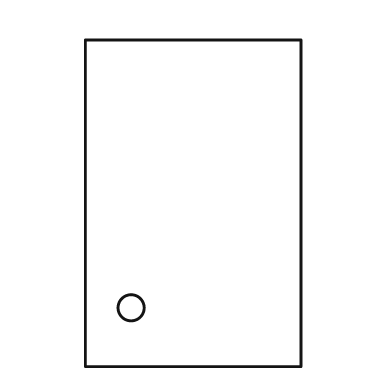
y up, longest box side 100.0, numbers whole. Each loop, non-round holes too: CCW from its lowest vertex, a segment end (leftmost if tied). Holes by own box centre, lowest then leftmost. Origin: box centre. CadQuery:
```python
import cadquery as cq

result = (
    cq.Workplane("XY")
    .moveTo(-33.0, -50.0)
    .lineTo(33.0, -50.0)
    .lineTo(33.0, 50.0)
    .lineTo(-33.0, 50.0)
    .close()
    .moveTo(-19.0, -32.0)
    .circle(4.0)
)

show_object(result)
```